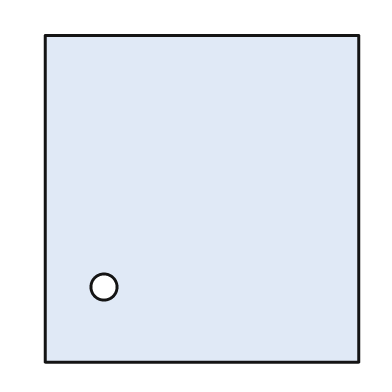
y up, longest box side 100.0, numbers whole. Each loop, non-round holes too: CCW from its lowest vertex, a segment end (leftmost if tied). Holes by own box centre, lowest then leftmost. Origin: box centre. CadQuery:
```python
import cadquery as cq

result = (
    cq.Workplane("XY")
    .moveTo(-48.0, -50.0)
    .lineTo(48.0, -50.0)
    .lineTo(48.0, 50.0)
    .lineTo(-48.0, 50.0)
    .close()
    .moveTo(-30.0, -27.0)
    .circle(4.0)
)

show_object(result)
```